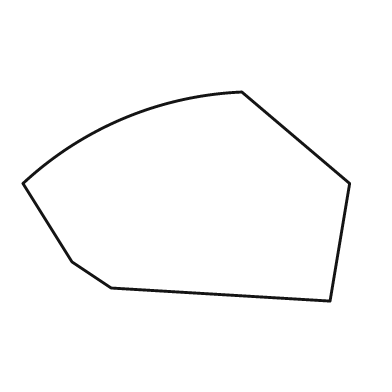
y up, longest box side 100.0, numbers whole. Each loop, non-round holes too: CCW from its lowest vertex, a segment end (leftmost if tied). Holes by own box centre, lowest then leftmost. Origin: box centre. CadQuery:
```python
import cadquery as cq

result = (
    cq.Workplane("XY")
    .moveTo(44.0, -32.0)
    .lineTo(50.0, 4.0)
    .lineTo(17.0, 32.0)
    .threePointArc((-19.0, 24.0), (-50.0, 4.0))
    .lineTo(-35.0, -20.0)
    .lineTo(-23.0, -28.0)
    .close()
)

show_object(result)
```